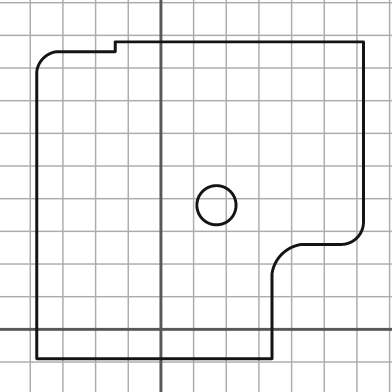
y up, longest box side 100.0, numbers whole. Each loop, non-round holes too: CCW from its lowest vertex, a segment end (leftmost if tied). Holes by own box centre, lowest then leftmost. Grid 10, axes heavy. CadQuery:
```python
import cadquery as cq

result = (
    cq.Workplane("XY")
    .moveTo(-38.0, -9.0)
    .lineTo(34.0, -9.0)
    .lineTo(34.0, 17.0)
    .threePointArc((37.0, 23.0), (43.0, 26.0))
    .lineTo(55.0, 26.0)
    .threePointArc((60.0, 28.0), (62.0, 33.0))
    .lineTo(62.0, 88.0)
    .lineTo(-14.0, 88.0)
    .lineTo(-14.0, 85.0)
    .lineTo(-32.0, 85.0)
    .threePointArc((-36.0, 83.0), (-38.0, 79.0))
    .close()
    .moveTo(17.0, 38.0)
    .circle(6.0)
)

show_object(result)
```